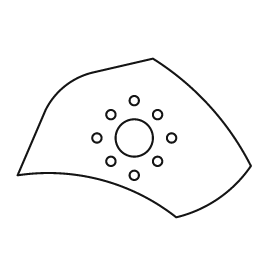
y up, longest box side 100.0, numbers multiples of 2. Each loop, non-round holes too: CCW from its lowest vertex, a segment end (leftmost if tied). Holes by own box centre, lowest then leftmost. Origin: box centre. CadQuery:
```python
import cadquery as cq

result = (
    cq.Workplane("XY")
    .moveTo(18.0, -34.0)
    .threePointArc((36.0, -26.0), (50.0, -12.0))
    .threePointArc((32.0, 14.0), (8.0, 34.0))
    .lineTo(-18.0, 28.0)
    .threePointArc((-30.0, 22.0), (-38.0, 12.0))
    .lineTo(-50.0, -16.0)
    .threePointArc((-14.0, -18.0), (18.0, -34.0))
    .close()
    .moveTo(0.0, -16.0)
    .circle(2.0)
    .moveTo(-10.0, -10.0)
    .circle(2.0)
    .moveTo(10.0, -10.0)
    .circle(2.0)
    .moveTo(-16.0, 0.0)
    .circle(2.0)
    .moveTo(0.0, 0.0)
    .circle(8.0)
    .moveTo(16.0, 0.0)
    .circle(2.0)
    .moveTo(-10.0, 10.0)
    .circle(2.0)
    .moveTo(10.0, 10.0)
    .circle(2.0)
    .moveTo(0.0, 16.0)
    .circle(2.0)
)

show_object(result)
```